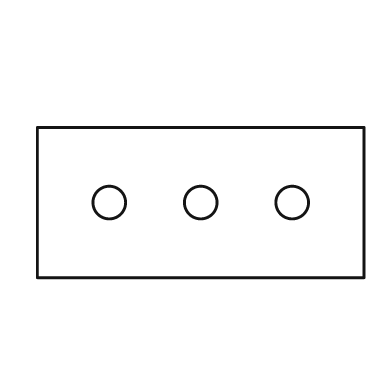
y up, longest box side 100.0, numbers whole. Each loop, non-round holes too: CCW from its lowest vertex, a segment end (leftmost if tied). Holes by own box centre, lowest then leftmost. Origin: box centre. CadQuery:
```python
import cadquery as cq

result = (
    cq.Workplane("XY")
    .moveTo(-50.0, -23.0)
    .lineTo(50.0, -23.0)
    .lineTo(50.0, 23.0)
    .lineTo(-50.0, 23.0)
    .close()
    .moveTo(-28.0, 0.0)
    .circle(5.0)
    .moveTo(0.0, 0.0)
    .circle(5.0)
    .moveTo(28.0, 0.0)
    .circle(5.0)
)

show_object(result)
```